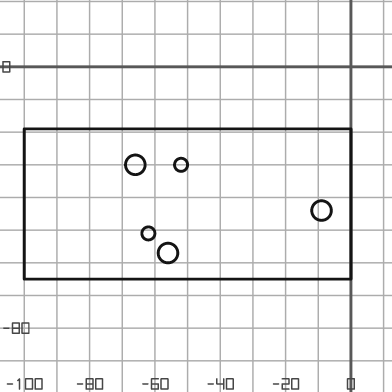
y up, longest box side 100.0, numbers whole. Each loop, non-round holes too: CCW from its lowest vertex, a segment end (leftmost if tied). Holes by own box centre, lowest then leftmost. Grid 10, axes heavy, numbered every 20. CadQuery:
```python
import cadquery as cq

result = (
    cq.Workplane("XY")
    .moveTo(-100.0, -65.0)
    .lineTo(0.0, -65.0)
    .lineTo(0.0, -19.0)
    .lineTo(-100.0, -19.0)
    .close()
    .moveTo(-56.0, -57.0)
    .circle(3.0)
    .moveTo(-62.0, -51.0)
    .circle(2.0)
    .moveTo(-9.0, -44.0)
    .circle(3.0)
    .moveTo(-66.0, -30.0)
    .circle(3.0)
    .moveTo(-52.0, -30.0)
    .circle(2.0)
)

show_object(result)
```